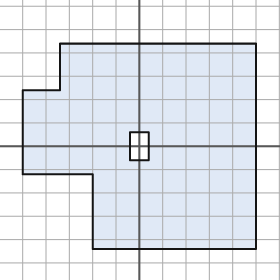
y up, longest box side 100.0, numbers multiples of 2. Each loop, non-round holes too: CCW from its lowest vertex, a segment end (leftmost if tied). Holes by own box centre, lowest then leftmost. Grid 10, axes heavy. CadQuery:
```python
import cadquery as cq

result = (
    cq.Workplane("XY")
    .moveTo(-20.0, -44.0)
    .lineTo(50.0, -44.0)
    .lineTo(50.0, 44.0)
    .lineTo(-34.0, 44.0)
    .lineTo(-34.0, 24.0)
    .lineTo(-50.0, 24.0)
    .lineTo(-50.0, -12.0)
    .lineTo(-20.0, -12.0)
    .close()
    .moveTo(-4.0, -6.0)
    .lineTo(4.0, -6.0)
    .lineTo(4.0, 6.0)
    .lineTo(-4.0, 6.0)
    .close()
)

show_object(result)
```